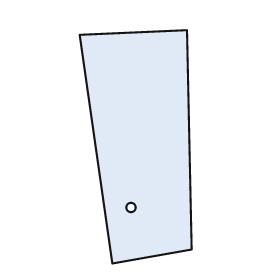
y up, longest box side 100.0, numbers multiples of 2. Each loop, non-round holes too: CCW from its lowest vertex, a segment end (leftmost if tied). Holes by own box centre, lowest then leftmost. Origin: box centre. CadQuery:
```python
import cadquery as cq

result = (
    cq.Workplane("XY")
    .moveTo(-10.0, -50.0)
    .lineTo(24.0, -44.0)
    .lineTo(22.0, 50.0)
    .lineTo(-24.0, 48.0)
    .close()
    .moveTo(-2.0, -26.0)
    .circle(2.0)
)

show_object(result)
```